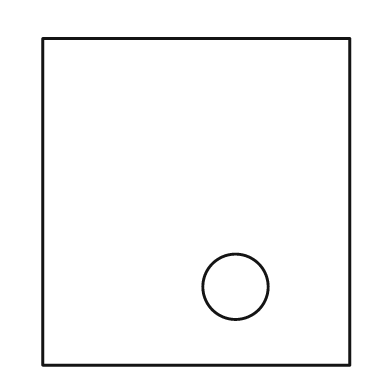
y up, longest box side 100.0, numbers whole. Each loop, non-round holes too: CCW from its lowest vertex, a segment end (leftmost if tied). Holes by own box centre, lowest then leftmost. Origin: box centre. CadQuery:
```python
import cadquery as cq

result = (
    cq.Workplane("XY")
    .moveTo(-47.0, -50.0)
    .lineTo(47.0, -50.0)
    .lineTo(47.0, 50.0)
    .lineTo(-47.0, 50.0)
    .close()
    .moveTo(12.0, -26.0)
    .circle(10.0)
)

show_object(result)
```